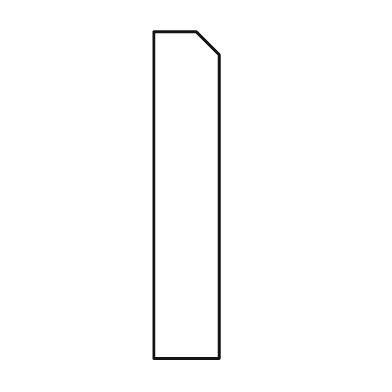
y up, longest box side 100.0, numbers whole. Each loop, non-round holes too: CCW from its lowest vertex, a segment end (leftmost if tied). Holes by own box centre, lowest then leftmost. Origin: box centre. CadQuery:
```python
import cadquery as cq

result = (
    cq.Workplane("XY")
    .moveTo(-10.0, -50.0)
    .lineTo(10.0, -50.0)
    .lineTo(10.0, 43.0)
    .lineTo(3.0, 50.0)
    .lineTo(-10.0, 50.0)
    .close()
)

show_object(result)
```